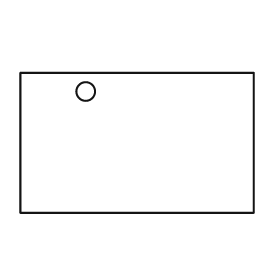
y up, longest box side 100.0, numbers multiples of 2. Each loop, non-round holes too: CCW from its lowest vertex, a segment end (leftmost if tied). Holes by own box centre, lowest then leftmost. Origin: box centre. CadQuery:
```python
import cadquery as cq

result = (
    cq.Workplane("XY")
    .moveTo(-50.0, -30.0)
    .lineTo(50.0, -30.0)
    .lineTo(50.0, 30.0)
    .lineTo(-50.0, 30.0)
    .close()
    .moveTo(-22.0, 22.0)
    .circle(4.0)
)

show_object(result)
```